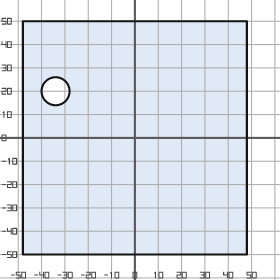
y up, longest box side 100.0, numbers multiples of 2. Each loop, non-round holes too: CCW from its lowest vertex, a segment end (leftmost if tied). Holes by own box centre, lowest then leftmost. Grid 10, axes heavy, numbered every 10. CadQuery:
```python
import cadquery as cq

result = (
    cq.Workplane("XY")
    .moveTo(-48.0, -50.0)
    .lineTo(48.0, -50.0)
    .lineTo(48.0, 50.0)
    .lineTo(-48.0, 50.0)
    .close()
    .moveTo(-34.0, 20.0)
    .circle(6.0)
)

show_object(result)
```